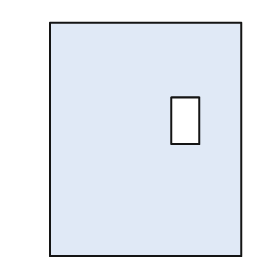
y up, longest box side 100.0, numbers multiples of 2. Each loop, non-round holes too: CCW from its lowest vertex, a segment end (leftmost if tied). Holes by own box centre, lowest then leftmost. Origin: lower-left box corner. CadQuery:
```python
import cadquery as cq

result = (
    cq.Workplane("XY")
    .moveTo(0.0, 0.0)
    .lineTo(82.0, 0.0)
    .lineTo(82.0, 100.0)
    .lineTo(0.0, 100.0)
    .close()
    .moveTo(52.0, 48.0)
    .lineTo(64.0, 48.0)
    .lineTo(64.0, 68.0)
    .lineTo(52.0, 68.0)
    .close()
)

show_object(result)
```